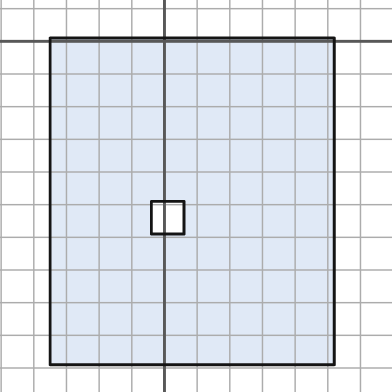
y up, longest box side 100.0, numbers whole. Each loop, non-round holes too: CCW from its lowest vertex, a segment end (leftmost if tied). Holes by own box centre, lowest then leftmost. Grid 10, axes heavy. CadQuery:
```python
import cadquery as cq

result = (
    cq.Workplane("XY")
    .moveTo(-35.0, -99.0)
    .lineTo(52.0, -99.0)
    .lineTo(52.0, 1.0)
    .lineTo(-35.0, 1.0)
    .close()
    .moveTo(-4.0, -59.0)
    .lineTo(6.0, -59.0)
    .lineTo(6.0, -49.0)
    .lineTo(-4.0, -49.0)
    .close()
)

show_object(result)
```